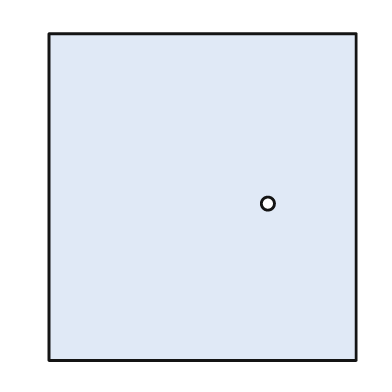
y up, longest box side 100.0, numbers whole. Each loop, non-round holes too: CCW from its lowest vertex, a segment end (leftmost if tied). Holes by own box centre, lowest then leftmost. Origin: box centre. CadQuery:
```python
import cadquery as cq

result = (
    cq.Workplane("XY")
    .moveTo(-47.0, -50.0)
    .lineTo(47.0, -50.0)
    .lineTo(47.0, 50.0)
    .lineTo(-47.0, 50.0)
    .close()
    .moveTo(20.0, -2.0)
    .circle(2.0)
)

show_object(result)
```